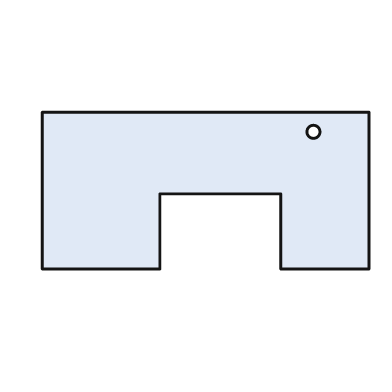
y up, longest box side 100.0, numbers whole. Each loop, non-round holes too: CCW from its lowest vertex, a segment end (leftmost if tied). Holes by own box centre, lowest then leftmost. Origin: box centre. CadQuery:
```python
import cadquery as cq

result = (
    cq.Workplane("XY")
    .moveTo(-50.0, -24.0)
    .lineTo(-14.0, -24.0)
    .lineTo(-14.0, -1.0)
    .lineTo(23.0, -1.0)
    .lineTo(23.0, -24.0)
    .lineTo(50.0, -24.0)
    .lineTo(50.0, 24.0)
    .lineTo(-50.0, 24.0)
    .close()
    .moveTo(33.0, 18.0)
    .circle(2.0)
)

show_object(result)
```